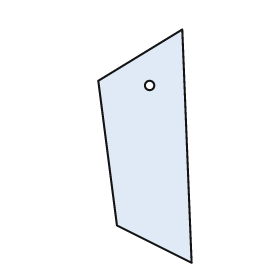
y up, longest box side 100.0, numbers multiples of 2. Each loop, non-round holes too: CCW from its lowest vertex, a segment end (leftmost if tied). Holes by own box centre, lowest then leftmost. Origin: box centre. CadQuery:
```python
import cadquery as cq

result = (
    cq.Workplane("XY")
    .moveTo(20.0, -50.0)
    .lineTo(16.0, 50.0)
    .lineTo(-20.0, 28.0)
    .lineTo(-12.0, -34.0)
    .close()
    .moveTo(2.0, 26.0)
    .circle(2.0)
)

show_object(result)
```